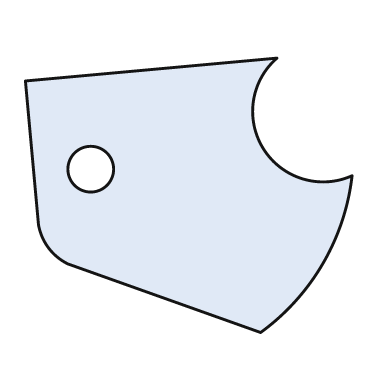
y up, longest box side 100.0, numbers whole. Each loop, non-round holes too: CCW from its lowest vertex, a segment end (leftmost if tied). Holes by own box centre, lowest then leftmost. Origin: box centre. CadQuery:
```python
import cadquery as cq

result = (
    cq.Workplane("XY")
    .moveTo(22.0, -42.0)
    .threePointArc((41.0, -21.0), (50.0, 6.0))
    .threePointArc((23.0, 14.0), (27.0, 42.0))
    .lineTo(-50.0, 35.0)
    .lineTo(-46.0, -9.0)
    .threePointArc((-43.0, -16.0), (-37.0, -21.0))
    .close()
    .moveTo(-30.0, 8.0)
    .circle(7.0)
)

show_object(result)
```